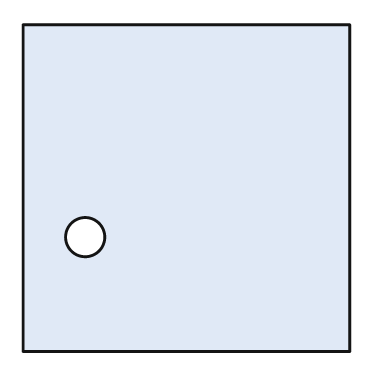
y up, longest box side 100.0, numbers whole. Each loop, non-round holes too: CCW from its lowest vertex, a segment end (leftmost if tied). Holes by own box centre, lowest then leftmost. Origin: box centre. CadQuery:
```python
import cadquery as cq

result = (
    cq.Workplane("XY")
    .moveTo(-50.0, -50.0)
    .lineTo(50.0, -50.0)
    .lineTo(50.0, 50.0)
    .lineTo(-50.0, 50.0)
    .close()
    .moveTo(-31.0, -15.0)
    .circle(6.0)
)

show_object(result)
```